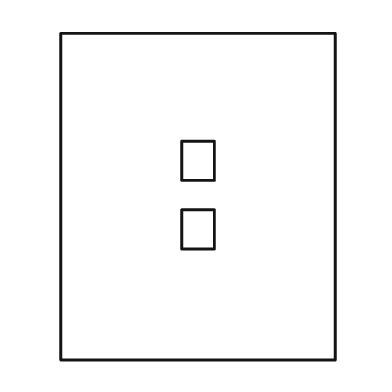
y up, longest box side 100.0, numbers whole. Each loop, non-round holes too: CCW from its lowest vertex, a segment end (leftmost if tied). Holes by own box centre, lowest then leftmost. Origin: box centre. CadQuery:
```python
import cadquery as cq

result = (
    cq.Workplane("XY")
    .moveTo(-42.0, -50.0)
    .lineTo(42.0, -50.0)
    .lineTo(42.0, 50.0)
    .lineTo(-42.0, 50.0)
    .close()
    .moveTo(-5.0, -16.0)
    .lineTo(5.0, -16.0)
    .lineTo(5.0, -4.0)
    .lineTo(-5.0, -4.0)
    .close()
    .moveTo(-5.0, 5.0)
    .lineTo(5.0, 5.0)
    .lineTo(5.0, 17.0)
    .lineTo(-5.0, 17.0)
    .close()
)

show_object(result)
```